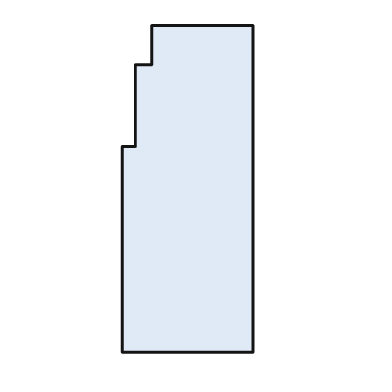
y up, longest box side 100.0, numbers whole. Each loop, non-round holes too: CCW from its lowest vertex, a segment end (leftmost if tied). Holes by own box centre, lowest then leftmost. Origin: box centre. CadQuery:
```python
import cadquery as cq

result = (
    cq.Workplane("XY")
    .moveTo(-20.0, -50.0)
    .lineTo(20.0, -50.0)
    .lineTo(20.0, 50.0)
    .lineTo(-11.0, 50.0)
    .lineTo(-11.0, 38.0)
    .lineTo(-16.0, 38.0)
    .lineTo(-16.0, 13.0)
    .lineTo(-20.0, 13.0)
    .close()
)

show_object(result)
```